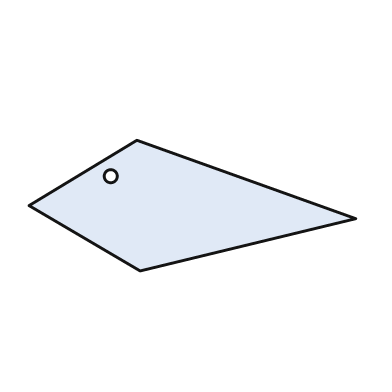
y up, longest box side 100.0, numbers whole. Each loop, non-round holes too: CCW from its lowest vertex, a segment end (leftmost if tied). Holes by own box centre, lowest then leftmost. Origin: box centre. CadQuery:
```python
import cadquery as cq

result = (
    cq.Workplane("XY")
    .moveTo(-16.0, -20.0)
    .lineTo(50.0, -4.0)
    .lineTo(-17.0, 20.0)
    .lineTo(-50.0, 0.0)
    .close()
    .moveTo(-25.0, 9.0)
    .circle(2.0)
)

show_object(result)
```